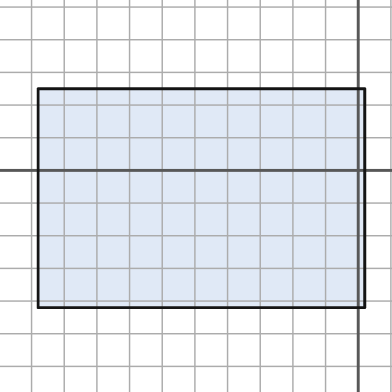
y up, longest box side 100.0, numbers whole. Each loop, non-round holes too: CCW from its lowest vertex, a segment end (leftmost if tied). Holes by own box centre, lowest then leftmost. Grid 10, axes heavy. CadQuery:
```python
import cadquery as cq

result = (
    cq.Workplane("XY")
    .moveTo(-98.0, -42.0)
    .lineTo(2.0, -42.0)
    .lineTo(2.0, 25.0)
    .lineTo(-98.0, 25.0)
    .close()
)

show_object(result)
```